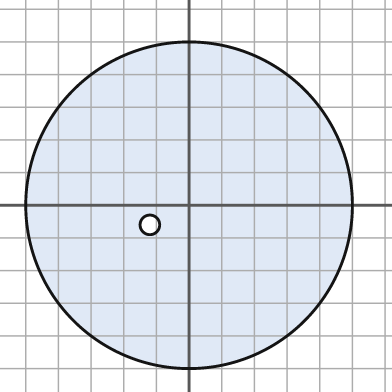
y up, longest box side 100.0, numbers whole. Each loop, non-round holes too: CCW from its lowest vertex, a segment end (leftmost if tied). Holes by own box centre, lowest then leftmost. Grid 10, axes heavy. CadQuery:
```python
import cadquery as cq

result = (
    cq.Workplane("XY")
    .moveTo(0.0, 0.0)
    .circle(50.0)
    .moveTo(-12.0, -6.0)
    .circle(3.0)
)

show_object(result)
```